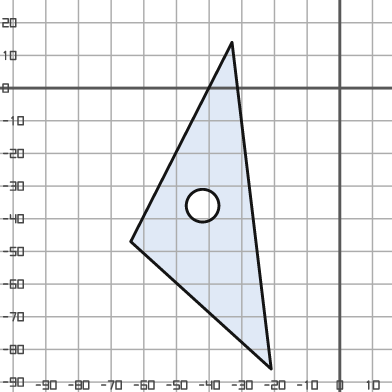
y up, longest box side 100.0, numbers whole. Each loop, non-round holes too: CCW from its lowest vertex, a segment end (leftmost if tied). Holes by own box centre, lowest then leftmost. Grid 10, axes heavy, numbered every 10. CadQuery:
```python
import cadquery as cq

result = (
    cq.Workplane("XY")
    .moveTo(-21.0, -86.0)
    .lineTo(-33.0, 14.0)
    .lineTo(-64.0, -47.0)
    .close()
    .moveTo(-42.0, -36.0)
    .circle(5.0)
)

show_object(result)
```